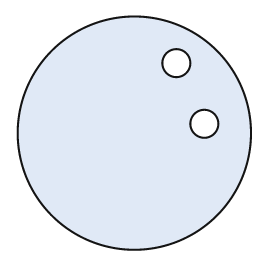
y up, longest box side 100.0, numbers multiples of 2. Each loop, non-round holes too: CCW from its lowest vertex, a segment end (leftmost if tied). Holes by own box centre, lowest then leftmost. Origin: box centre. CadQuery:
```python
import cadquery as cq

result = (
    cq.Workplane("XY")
    .moveTo(0.0, 0.0)
    .circle(50.0)
    .moveTo(30.0, 4.0)
    .circle(6.0)
    .moveTo(18.0, 30.0)
    .circle(6.0)
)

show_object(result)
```